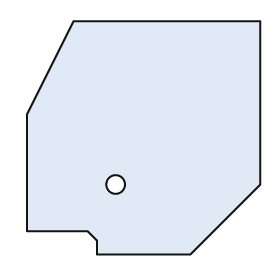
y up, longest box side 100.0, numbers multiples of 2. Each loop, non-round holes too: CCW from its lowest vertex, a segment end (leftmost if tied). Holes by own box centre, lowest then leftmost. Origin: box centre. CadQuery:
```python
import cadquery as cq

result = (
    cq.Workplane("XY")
    .moveTo(-20.0, -50.0)
    .lineTo(20.0, -50.0)
    .lineTo(50.0, -20.0)
    .lineTo(50.0, 50.0)
    .lineTo(-30.0, 50.0)
    .lineTo(-50.0, 10.0)
    .lineTo(-50.0, -40.0)
    .lineTo(-24.0, -40.0)
    .lineTo(-20.0, -44.0)
    .close()
    .moveTo(-12.0, -20.0)
    .circle(4.0)
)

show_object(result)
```